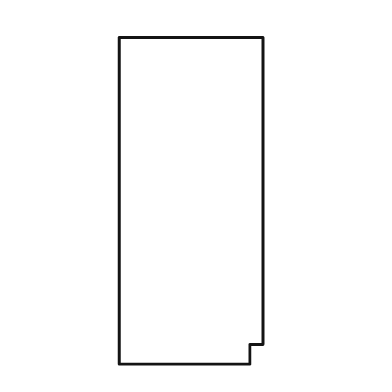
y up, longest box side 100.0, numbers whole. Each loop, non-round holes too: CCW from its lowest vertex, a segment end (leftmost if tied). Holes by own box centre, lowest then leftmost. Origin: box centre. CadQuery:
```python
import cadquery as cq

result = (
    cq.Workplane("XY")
    .moveTo(-22.0, -50.0)
    .lineTo(18.0, -50.0)
    .lineTo(18.0, -44.0)
    .lineTo(22.0, -44.0)
    .lineTo(22.0, 50.0)
    .lineTo(-22.0, 50.0)
    .close()
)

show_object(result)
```